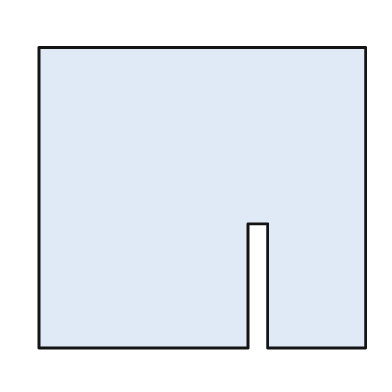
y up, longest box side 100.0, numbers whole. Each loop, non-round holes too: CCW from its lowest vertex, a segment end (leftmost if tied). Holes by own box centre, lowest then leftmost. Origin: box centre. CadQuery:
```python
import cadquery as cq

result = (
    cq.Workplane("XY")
    .moveTo(-50.0, -46.0)
    .lineTo(14.0, -46.0)
    .lineTo(14.0, -8.0)
    .lineTo(20.0, -8.0)
    .lineTo(20.0, -46.0)
    .lineTo(50.0, -46.0)
    .lineTo(50.0, 46.0)
    .lineTo(-50.0, 46.0)
    .close()
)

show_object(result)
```